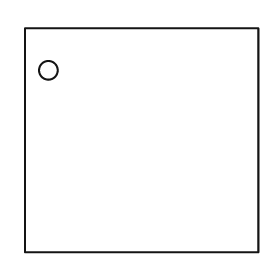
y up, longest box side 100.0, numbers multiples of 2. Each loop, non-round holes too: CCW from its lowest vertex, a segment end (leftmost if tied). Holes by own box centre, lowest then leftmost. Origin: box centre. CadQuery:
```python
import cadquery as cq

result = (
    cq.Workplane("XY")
    .moveTo(-50.0, -48.0)
    .lineTo(50.0, -48.0)
    .lineTo(50.0, 48.0)
    .lineTo(-50.0, 48.0)
    .close()
    .moveTo(-40.0, 30.0)
    .circle(4.0)
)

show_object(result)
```